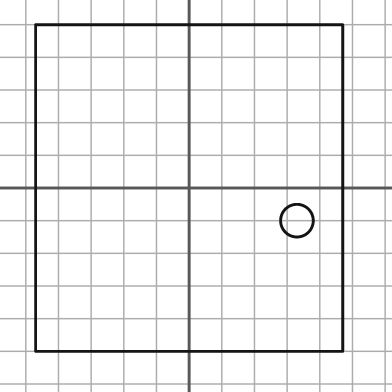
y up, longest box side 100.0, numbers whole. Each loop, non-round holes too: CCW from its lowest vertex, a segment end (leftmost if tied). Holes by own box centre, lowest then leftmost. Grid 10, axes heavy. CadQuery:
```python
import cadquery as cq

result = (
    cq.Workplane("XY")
    .moveTo(-47.0, -50.0)
    .lineTo(47.0, -50.0)
    .lineTo(47.0, 50.0)
    .lineTo(-47.0, 50.0)
    .close()
    .moveTo(33.0, -10.0)
    .circle(5.0)
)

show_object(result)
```